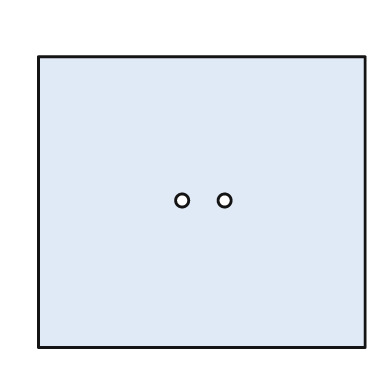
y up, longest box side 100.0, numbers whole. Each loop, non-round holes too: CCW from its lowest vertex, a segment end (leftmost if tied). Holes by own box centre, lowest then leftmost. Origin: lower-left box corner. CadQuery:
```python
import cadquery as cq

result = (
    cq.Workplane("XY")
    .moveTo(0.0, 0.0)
    .lineTo(100.0, 0.0)
    .lineTo(100.0, 89.0)
    .lineTo(0.0, 89.0)
    .close()
    .moveTo(44.0, 45.0)
    .circle(2.0)
    .moveTo(57.0, 45.0)
    .circle(2.0)
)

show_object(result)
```